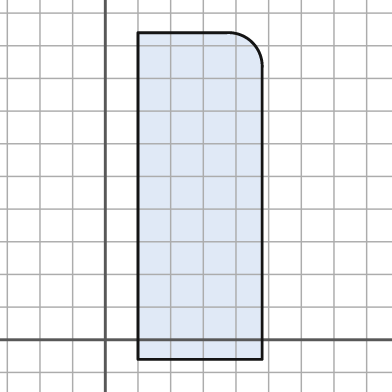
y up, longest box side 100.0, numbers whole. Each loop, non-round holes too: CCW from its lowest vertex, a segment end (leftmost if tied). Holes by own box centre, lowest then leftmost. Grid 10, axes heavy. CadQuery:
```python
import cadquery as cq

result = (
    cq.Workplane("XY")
    .moveTo(10.0, -6.0)
    .lineTo(48.0, -6.0)
    .lineTo(48.0, 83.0)
    .threePointArc((45.0, 91.0), (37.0, 94.0))
    .lineTo(10.0, 94.0)
    .close()
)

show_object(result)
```